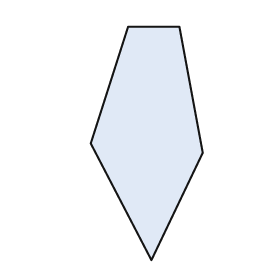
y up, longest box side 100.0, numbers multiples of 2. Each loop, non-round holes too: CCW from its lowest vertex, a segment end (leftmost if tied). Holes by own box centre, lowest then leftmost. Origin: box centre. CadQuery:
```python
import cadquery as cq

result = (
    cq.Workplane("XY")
    .moveTo(2.0, -50.0)
    .lineTo(24.0, -4.0)
    .lineTo(14.0, 50.0)
    .lineTo(-8.0, 50.0)
    .lineTo(-24.0, 0.0)
    .close()
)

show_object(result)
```